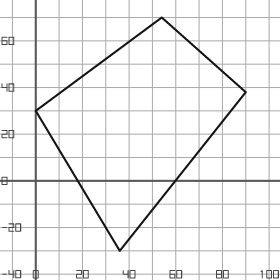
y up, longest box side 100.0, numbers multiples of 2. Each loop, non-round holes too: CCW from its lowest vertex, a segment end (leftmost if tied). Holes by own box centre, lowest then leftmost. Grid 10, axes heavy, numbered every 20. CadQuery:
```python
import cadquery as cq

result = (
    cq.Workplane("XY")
    .moveTo(36.0, -30.0)
    .lineTo(90.0, 38.0)
    .lineTo(54.0, 70.0)
    .lineTo(0.0, 30.0)
    .close()
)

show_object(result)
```